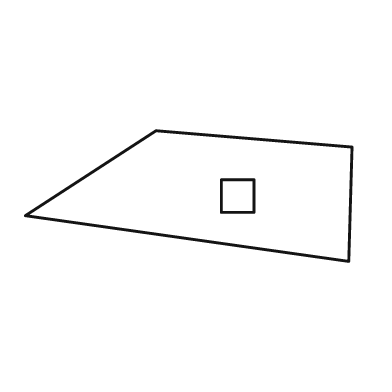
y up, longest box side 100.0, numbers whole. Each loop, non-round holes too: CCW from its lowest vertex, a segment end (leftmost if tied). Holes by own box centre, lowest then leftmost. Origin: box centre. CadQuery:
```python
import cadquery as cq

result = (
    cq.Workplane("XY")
    .moveTo(49.0, -20.0)
    .lineTo(50.0, 15.0)
    .lineTo(-10.0, 20.0)
    .lineTo(-50.0, -6.0)
    .close()
    .moveTo(10.0, -5.0)
    .lineTo(20.0, -5.0)
    .lineTo(20.0, 5.0)
    .lineTo(10.0, 5.0)
    .close()
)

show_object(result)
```